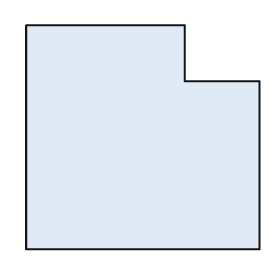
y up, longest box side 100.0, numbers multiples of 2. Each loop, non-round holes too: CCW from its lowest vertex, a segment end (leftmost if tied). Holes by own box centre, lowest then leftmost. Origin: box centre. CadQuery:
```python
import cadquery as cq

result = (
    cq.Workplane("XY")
    .moveTo(-50.0, -48.0)
    .lineTo(50.0, -48.0)
    .lineTo(50.0, 24.0)
    .lineTo(18.0, 24.0)
    .lineTo(18.0, 48.0)
    .lineTo(-50.0, 48.0)
    .close()
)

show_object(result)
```